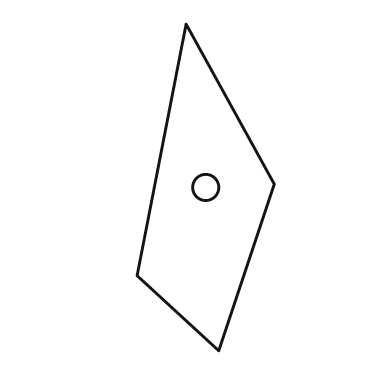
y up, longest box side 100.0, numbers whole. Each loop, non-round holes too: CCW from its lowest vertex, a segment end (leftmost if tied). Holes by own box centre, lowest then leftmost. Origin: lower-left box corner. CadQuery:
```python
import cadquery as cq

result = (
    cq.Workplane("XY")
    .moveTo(25.0, 0.0)
    .lineTo(42.0, 51.0)
    .lineTo(15.0, 100.0)
    .lineTo(0.0, 23.0)
    .close()
    .moveTo(21.0, 50.0)
    .circle(4.0)
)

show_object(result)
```